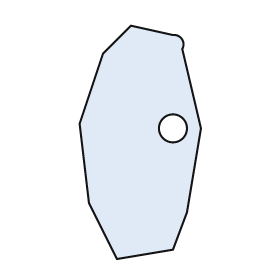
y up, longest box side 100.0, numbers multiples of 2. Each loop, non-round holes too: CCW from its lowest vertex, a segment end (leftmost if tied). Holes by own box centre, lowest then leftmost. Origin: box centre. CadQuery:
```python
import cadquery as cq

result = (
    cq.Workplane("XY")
    .moveTo(-10.0, -50.0)
    .lineTo(14.0, -46.0)
    .lineTo(20.0, -30.0)
    .lineTo(26.0, 6.0)
    .lineTo(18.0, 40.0)
    .threePointArc((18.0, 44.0), (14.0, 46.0))
    .lineTo(-4.0, 50.0)
    .lineTo(-16.0, 38.0)
    .lineTo(-26.0, 8.0)
    .lineTo(-22.0, -26.0)
    .close()
    .moveTo(14.0, 6.0)
    .circle(6.0)
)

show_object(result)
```